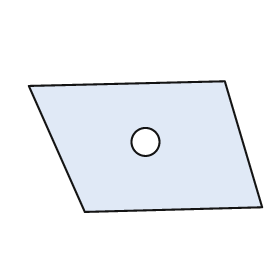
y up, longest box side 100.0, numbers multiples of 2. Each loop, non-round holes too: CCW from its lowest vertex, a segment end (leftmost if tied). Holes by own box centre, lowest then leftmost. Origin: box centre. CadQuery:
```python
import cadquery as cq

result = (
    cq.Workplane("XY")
    .moveTo(-26.0, -28.0)
    .lineTo(50.0, -26.0)
    .lineTo(34.0, 28.0)
    .lineTo(-50.0, 26.0)
    .close()
    .moveTo(0.0, 2.0)
    .circle(6.0)
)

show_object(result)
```